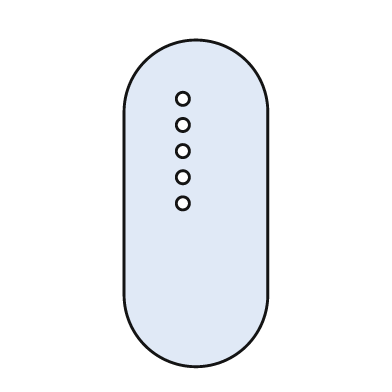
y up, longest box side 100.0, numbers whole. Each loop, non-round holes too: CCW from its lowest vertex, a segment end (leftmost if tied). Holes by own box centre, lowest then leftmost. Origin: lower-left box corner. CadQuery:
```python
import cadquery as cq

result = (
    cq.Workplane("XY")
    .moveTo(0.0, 22.0)
    .threePointArc((22.0, 0.0), (44.0, 22.0))
    .lineTo(44.0, 78.0)
    .threePointArc((22.0, 100.0), (0.0, 78.0))
    .close()
    .moveTo(18.0, 50.0)
    .circle(2.0)
    .moveTo(18.0, 58.0)
    .circle(2.0)
    .moveTo(18.0, 66.0)
    .circle(2.0)
    .moveTo(18.0, 74.0)
    .circle(2.0)
    .moveTo(18.0, 82.0)
    .circle(2.0)
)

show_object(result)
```